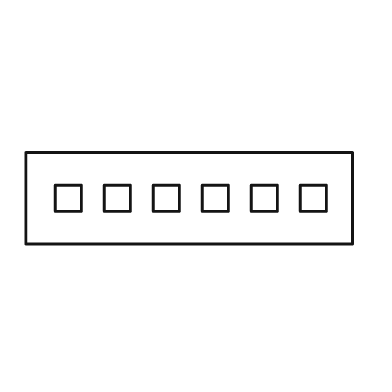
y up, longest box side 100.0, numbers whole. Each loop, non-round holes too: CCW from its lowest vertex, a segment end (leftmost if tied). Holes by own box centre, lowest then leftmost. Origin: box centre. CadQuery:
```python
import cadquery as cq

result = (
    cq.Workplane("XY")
    .moveTo(-50.0, -14.0)
    .lineTo(50.0, -14.0)
    .lineTo(50.0, 14.0)
    .lineTo(-50.0, 14.0)
    .close()
    .moveTo(-41.0, -4.0)
    .lineTo(-33.0, -4.0)
    .lineTo(-33.0, 4.0)
    .lineTo(-41.0, 4.0)
    .close()
    .moveTo(-26.0, -4.0)
    .lineTo(-18.0, -4.0)
    .lineTo(-18.0, 4.0)
    .lineTo(-26.0, 4.0)
    .close()
    .moveTo(-11.0, -4.0)
    .lineTo(-3.0, -4.0)
    .lineTo(-3.0, 4.0)
    .lineTo(-11.0, 4.0)
    .close()
    .moveTo(4.0, -4.0)
    .lineTo(12.0, -4.0)
    .lineTo(12.0, 4.0)
    .lineTo(4.0, 4.0)
    .close()
    .moveTo(19.0, -4.0)
    .lineTo(27.0, -4.0)
    .lineTo(27.0, 4.0)
    .lineTo(19.0, 4.0)
    .close()
    .moveTo(34.0, -4.0)
    .lineTo(42.0, -4.0)
    .lineTo(42.0, 4.0)
    .lineTo(34.0, 4.0)
    .close()
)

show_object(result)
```